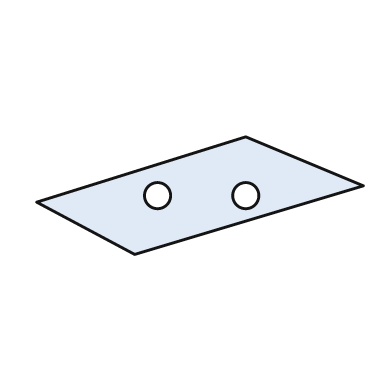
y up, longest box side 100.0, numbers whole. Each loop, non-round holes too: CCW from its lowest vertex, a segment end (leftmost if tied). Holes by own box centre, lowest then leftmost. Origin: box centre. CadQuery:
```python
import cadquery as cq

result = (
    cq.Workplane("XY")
    .moveTo(-20.0, -18.0)
    .lineTo(50.0, 3.0)
    .lineTo(14.0, 18.0)
    .lineTo(-50.0, -2.0)
    .close()
    .moveTo(-13.0, 0.0)
    .circle(4.0)
    .moveTo(14.0, 0.0)
    .circle(4.0)
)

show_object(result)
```